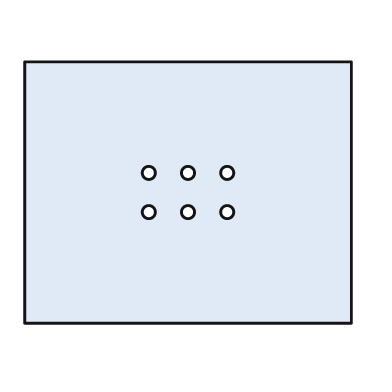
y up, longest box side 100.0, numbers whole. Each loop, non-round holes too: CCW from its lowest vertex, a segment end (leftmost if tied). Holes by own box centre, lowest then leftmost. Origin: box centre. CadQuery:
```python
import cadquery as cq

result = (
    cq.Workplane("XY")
    .moveTo(-50.0, -40.0)
    .lineTo(50.0, -40.0)
    .lineTo(50.0, 40.0)
    .lineTo(-50.0, 40.0)
    .close()
    .moveTo(-12.0, -6.0)
    .circle(2.0)
    .moveTo(0.0, -6.0)
    .circle(2.0)
    .moveTo(12.0, -6.0)
    .circle(2.0)
    .moveTo(-12.0, 6.0)
    .circle(2.0)
    .moveTo(0.0, 6.0)
    .circle(2.0)
    .moveTo(12.0, 6.0)
    .circle(2.0)
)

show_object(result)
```